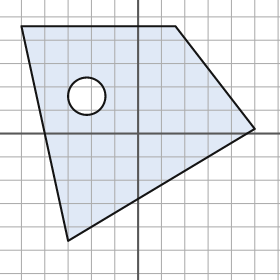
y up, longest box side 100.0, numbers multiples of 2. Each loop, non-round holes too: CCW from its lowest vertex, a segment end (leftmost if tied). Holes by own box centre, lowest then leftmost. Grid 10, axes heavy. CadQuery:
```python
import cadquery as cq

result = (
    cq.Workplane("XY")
    .moveTo(-30.0, -46.0)
    .lineTo(50.0, 2.0)
    .lineTo(16.0, 46.0)
    .lineTo(-50.0, 46.0)
    .close()
    .moveTo(-22.0, 16.0)
    .circle(8.0)
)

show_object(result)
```